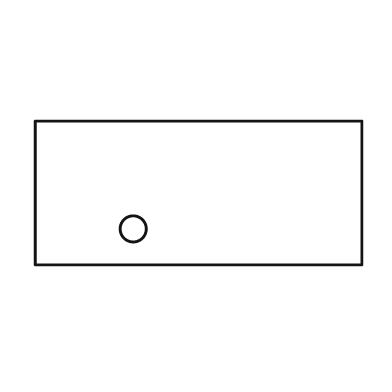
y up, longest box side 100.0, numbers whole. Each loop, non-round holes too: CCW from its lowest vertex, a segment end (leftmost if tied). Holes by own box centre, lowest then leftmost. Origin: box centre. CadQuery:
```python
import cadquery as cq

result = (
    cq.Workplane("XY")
    .moveTo(-50.0, -22.0)
    .lineTo(50.0, -22.0)
    .lineTo(50.0, 22.0)
    .lineTo(-50.0, 22.0)
    .close()
    .moveTo(-20.0, -11.0)
    .circle(4.0)
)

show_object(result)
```